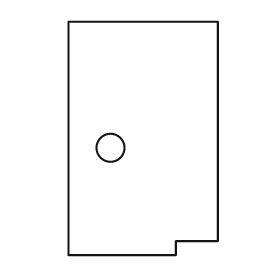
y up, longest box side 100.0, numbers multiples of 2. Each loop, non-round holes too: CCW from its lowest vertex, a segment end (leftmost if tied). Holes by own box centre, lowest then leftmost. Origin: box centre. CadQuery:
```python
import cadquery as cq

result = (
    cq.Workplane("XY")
    .moveTo(-32.0, -50.0)
    .lineTo(14.0, -50.0)
    .lineTo(14.0, -44.0)
    .lineTo(32.0, -44.0)
    .lineTo(32.0, 50.0)
    .lineTo(-32.0, 50.0)
    .close()
    .moveTo(-14.0, -4.0)
    .circle(6.0)
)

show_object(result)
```